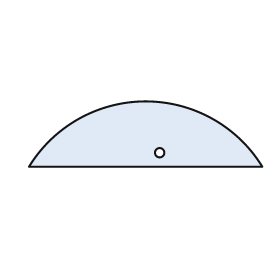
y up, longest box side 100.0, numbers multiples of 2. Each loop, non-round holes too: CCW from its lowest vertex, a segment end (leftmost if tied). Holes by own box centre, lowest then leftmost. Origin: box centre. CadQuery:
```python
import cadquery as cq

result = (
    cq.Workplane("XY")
    .moveTo(-50.0, -14.0)
    .lineTo(50.0, -14.0)
    .threePointArc((0.0, 14.0), (-50.0, -14.0))
    .close()
    .moveTo(6.0, -8.0)
    .circle(2.0)
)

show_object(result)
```